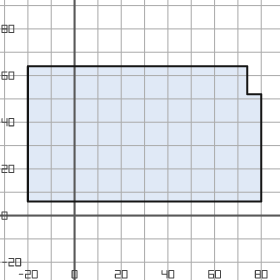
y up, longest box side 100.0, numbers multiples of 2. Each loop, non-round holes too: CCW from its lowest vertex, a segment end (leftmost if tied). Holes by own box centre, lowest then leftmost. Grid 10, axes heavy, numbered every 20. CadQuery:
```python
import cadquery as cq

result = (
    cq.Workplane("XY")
    .moveTo(-20.0, 6.0)
    .lineTo(80.0, 6.0)
    .lineTo(80.0, 52.0)
    .lineTo(74.0, 52.0)
    .lineTo(74.0, 64.0)
    .lineTo(-20.0, 64.0)
    .close()
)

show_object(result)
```